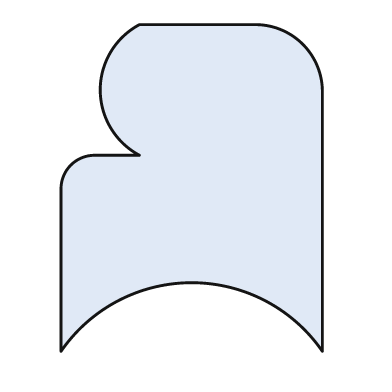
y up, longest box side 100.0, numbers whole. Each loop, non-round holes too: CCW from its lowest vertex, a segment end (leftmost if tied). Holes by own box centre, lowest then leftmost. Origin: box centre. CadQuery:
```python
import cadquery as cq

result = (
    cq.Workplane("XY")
    .moveTo(-40.0, -50.0)
    .threePointArc((0.0, -29.0), (40.0, -50.0))
    .lineTo(40.0, 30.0)
    .threePointArc((34.0, 44.0), (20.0, 50.0))
    .lineTo(-16.0, 50.0)
    .threePointArc((-28.0, 30.0), (-16.0, 10.0))
    .lineTo(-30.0, 10.0)
    .threePointArc((-37.0, 7.0), (-40.0, 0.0))
    .close()
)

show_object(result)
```